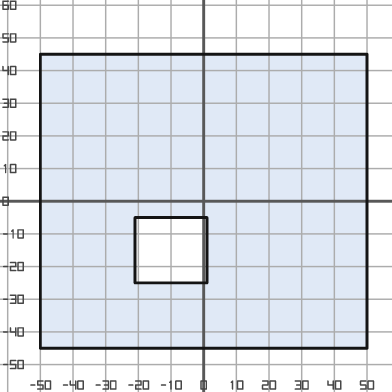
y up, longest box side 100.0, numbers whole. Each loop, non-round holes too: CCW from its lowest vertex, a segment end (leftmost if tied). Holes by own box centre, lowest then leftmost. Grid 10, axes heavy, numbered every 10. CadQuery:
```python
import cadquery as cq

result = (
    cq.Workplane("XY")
    .moveTo(-50.0, -45.0)
    .lineTo(50.0, -45.0)
    .lineTo(50.0, 45.0)
    .lineTo(-50.0, 45.0)
    .close()
    .moveTo(-21.0, -25.0)
    .lineTo(1.0, -25.0)
    .lineTo(1.0, -5.0)
    .lineTo(-21.0, -5.0)
    .close()
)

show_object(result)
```